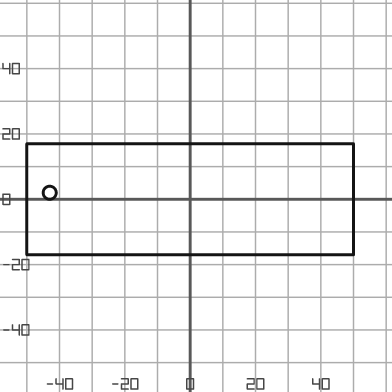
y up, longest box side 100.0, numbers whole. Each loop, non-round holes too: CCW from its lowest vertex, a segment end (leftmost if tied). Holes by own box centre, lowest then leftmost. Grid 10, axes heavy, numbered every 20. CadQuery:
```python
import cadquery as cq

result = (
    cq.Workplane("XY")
    .moveTo(-50.0, -17.0)
    .lineTo(50.0, -17.0)
    .lineTo(50.0, 17.0)
    .lineTo(-50.0, 17.0)
    .close()
    .moveTo(-43.0, 2.0)
    .circle(2.0)
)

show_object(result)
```